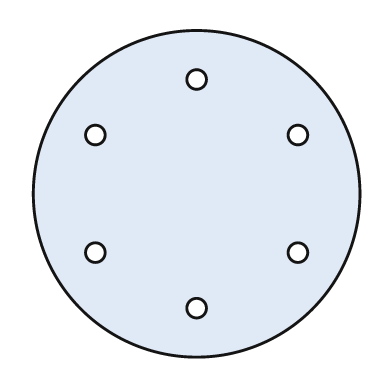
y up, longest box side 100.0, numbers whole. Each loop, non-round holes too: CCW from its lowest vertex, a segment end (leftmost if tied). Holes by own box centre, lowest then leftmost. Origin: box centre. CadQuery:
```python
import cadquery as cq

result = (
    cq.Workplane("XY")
    .moveTo(0.0, 0.0)
    .circle(50.0)
    .moveTo(0.0, -35.0)
    .circle(3.0)
    .moveTo(-31.0, -18.0)
    .circle(3.0)
    .moveTo(31.0, -18.0)
    .circle(3.0)
    .moveTo(-31.0, 18.0)
    .circle(3.0)
    .moveTo(31.0, 18.0)
    .circle(3.0)
    .moveTo(0.0, 35.0)
    .circle(3.0)
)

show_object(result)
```